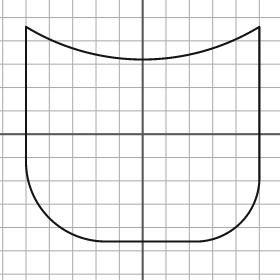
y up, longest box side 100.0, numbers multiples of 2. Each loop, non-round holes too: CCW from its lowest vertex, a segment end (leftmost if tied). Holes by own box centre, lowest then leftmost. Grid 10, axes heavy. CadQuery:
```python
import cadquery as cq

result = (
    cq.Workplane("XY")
    .moveTo(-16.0, -46.0)
    .lineTo(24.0, -46.0)
    .threePointArc((42.0, -38.0), (50.0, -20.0))
    .lineTo(50.0, 46.0)
    .threePointArc((0.0, 32.0), (-50.0, 46.0))
    .lineTo(-50.0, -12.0)
    .threePointArc((-40.0, -36.0), (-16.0, -46.0))
    .close()
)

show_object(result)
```